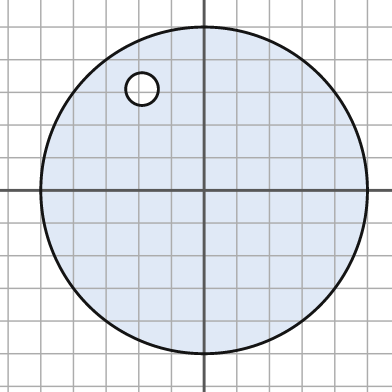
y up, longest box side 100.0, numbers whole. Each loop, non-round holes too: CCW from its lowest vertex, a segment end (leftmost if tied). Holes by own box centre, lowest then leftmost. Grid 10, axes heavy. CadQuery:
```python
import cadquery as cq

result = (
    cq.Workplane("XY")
    .moveTo(0.0, 0.0)
    .circle(50.0)
    .moveTo(-19.0, 31.0)
    .circle(5.0)
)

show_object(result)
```